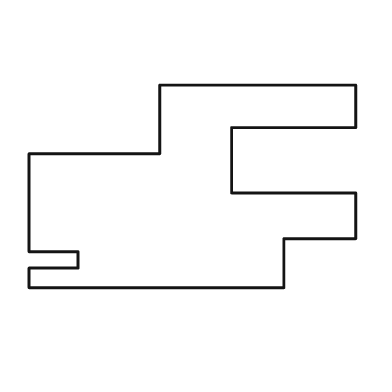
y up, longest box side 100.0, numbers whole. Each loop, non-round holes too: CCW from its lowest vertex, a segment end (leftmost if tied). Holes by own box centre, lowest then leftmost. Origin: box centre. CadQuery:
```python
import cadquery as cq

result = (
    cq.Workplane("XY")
    .moveTo(-50.0, -31.0)
    .lineTo(28.0, -31.0)
    .lineTo(28.0, -16.0)
    .lineTo(50.0, -16.0)
    .lineTo(50.0, -2.0)
    .lineTo(12.0, -2.0)
    .lineTo(12.0, 18.0)
    .lineTo(50.0, 18.0)
    .lineTo(50.0, 31.0)
    .lineTo(-10.0, 31.0)
    .lineTo(-10.0, 10.0)
    .lineTo(-50.0, 10.0)
    .lineTo(-50.0, -20.0)
    .lineTo(-35.0, -20.0)
    .lineTo(-35.0, -25.0)
    .lineTo(-50.0, -25.0)
    .close()
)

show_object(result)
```